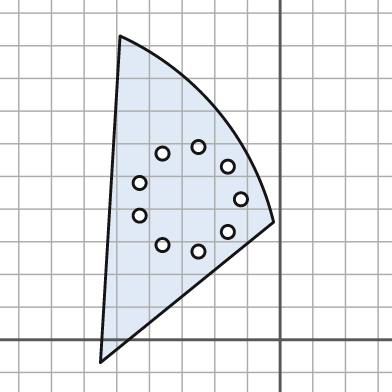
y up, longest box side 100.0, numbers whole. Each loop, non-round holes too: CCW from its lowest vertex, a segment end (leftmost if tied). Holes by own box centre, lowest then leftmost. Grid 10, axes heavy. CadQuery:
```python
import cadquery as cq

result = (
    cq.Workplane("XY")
    .moveTo(-55.0, -7.0)
    .lineTo(-2.0, 36.0)
    .threePointArc((-19.0, 70.0), (-49.0, 93.0))
    .close()
    .moveTo(-25.0, 27.0)
    .circle(2.0)
    .moveTo(-36.0, 29.0)
    .circle(2.0)
    .moveTo(-16.0, 33.0)
    .circle(2.0)
    .moveTo(-43.0, 38.0)
    .circle(2.0)
    .moveTo(-12.0, 43.0)
    .circle(2.0)
    .moveTo(-43.0, 48.0)
    .circle(2.0)
    .moveTo(-16.0, 53.0)
    .circle(2.0)
    .moveTo(-36.0, 57.0)
    .circle(2.0)
    .moveTo(-25.0, 59.0)
    .circle(2.0)
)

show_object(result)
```